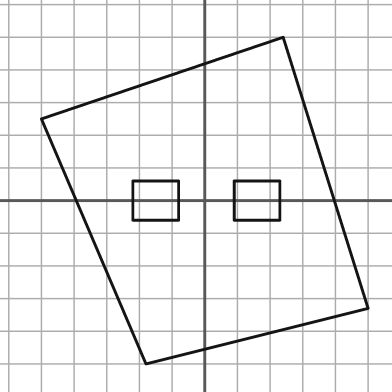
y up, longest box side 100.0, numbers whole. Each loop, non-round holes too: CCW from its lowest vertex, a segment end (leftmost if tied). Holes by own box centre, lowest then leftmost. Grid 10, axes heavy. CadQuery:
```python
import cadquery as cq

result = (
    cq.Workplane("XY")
    .moveTo(-18.0, -50.0)
    .lineTo(50.0, -33.0)
    .lineTo(24.0, 50.0)
    .lineTo(-50.0, 25.0)
    .close()
    .moveTo(-22.0, -6.0)
    .lineTo(-8.0, -6.0)
    .lineTo(-8.0, 6.0)
    .lineTo(-22.0, 6.0)
    .close()
    .moveTo(9.0, -6.0)
    .lineTo(23.0, -6.0)
    .lineTo(23.0, 6.0)
    .lineTo(9.0, 6.0)
    .close()
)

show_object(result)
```